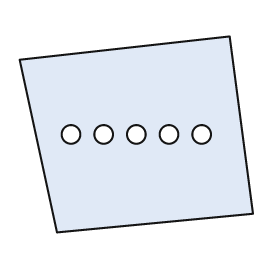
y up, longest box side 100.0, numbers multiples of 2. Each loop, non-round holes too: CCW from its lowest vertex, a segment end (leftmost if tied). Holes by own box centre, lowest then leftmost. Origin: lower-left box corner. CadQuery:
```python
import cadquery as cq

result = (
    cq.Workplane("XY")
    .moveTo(16.0, 0.0)
    .lineTo(100.0, 8.0)
    .lineTo(90.0, 84.0)
    .lineTo(0.0, 74.0)
    .close()
    .moveTo(22.0, 42.0)
    .circle(4.0)
    .moveTo(36.0, 42.0)
    .circle(4.0)
    .moveTo(50.0, 42.0)
    .circle(4.0)
    .moveTo(64.0, 42.0)
    .circle(4.0)
    .moveTo(78.0, 42.0)
    .circle(4.0)
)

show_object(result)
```